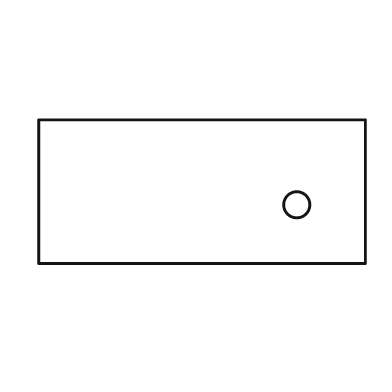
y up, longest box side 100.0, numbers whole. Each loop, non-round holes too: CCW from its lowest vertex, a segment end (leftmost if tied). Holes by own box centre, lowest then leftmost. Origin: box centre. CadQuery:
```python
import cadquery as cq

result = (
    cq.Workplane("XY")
    .moveTo(-50.0, -22.0)
    .lineTo(50.0, -22.0)
    .lineTo(50.0, 22.0)
    .lineTo(-50.0, 22.0)
    .close()
    .moveTo(29.0, -4.0)
    .circle(4.0)
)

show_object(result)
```